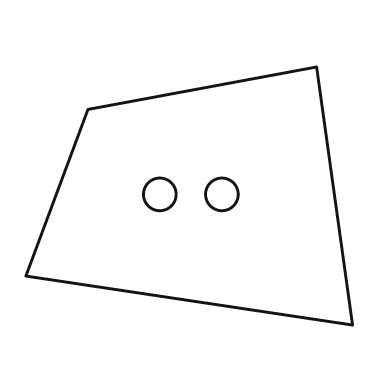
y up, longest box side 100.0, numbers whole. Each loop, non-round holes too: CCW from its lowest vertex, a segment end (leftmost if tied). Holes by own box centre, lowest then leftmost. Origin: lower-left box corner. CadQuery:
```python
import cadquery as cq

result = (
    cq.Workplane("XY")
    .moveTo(100.0, 0.0)
    .lineTo(89.0, 79.0)
    .lineTo(19.0, 66.0)
    .lineTo(0.0, 15.0)
    .close()
    .moveTo(41.0, 40.0)
    .circle(5.0)
    .moveTo(60.0, 40.0)
    .circle(5.0)
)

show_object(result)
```